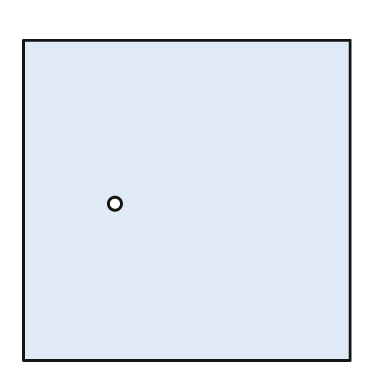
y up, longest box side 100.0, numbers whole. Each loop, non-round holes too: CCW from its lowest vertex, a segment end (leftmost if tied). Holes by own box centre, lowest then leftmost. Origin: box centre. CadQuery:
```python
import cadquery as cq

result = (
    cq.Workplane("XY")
    .moveTo(-50.0, -49.0)
    .lineTo(50.0, -49.0)
    .lineTo(50.0, 49.0)
    .lineTo(-50.0, 49.0)
    .close()
    .moveTo(-22.0, -1.0)
    .circle(2.0)
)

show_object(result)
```